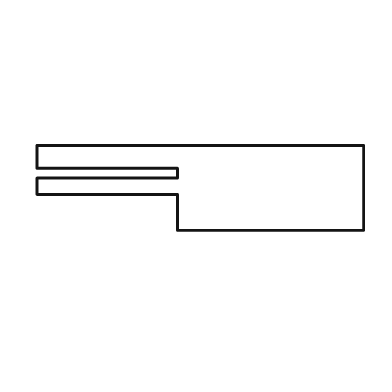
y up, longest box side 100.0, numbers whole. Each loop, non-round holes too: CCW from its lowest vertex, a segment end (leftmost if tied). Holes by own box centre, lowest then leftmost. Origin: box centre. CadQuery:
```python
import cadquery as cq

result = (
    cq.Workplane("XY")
    .moveTo(-7.0, -13.0)
    .lineTo(50.0, -13.0)
    .lineTo(50.0, 13.0)
    .lineTo(-50.0, 13.0)
    .lineTo(-50.0, 6.0)
    .lineTo(-7.0, 6.0)
    .lineTo(-7.0, 3.0)
    .lineTo(-50.0, 3.0)
    .lineTo(-50.0, -2.0)
    .lineTo(-7.0, -2.0)
    .close()
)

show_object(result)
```